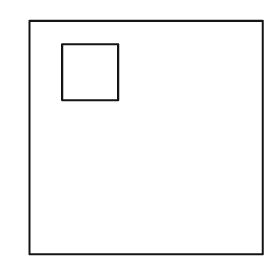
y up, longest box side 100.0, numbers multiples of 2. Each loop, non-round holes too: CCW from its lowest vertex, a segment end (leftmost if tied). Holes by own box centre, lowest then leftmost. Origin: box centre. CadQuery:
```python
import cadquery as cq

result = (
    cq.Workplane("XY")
    .moveTo(-50.0, -50.0)
    .lineTo(50.0, -50.0)
    .lineTo(50.0, 50.0)
    .lineTo(-50.0, 50.0)
    .close()
    .moveTo(-36.0, 16.0)
    .lineTo(-12.0, 16.0)
    .lineTo(-12.0, 40.0)
    .lineTo(-36.0, 40.0)
    .close()
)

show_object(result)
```